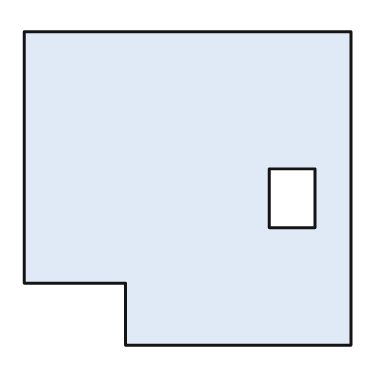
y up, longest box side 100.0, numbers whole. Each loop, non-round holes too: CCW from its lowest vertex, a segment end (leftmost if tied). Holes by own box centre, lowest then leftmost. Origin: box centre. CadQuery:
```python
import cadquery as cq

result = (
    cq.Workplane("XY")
    .moveTo(-19.0, -48.0)
    .lineTo(50.0, -48.0)
    .lineTo(50.0, 48.0)
    .lineTo(-50.0, 48.0)
    .lineTo(-50.0, -29.0)
    .lineTo(-19.0, -29.0)
    .close()
    .moveTo(25.0, -12.0)
    .lineTo(39.0, -12.0)
    .lineTo(39.0, 6.0)
    .lineTo(25.0, 6.0)
    .close()
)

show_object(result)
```